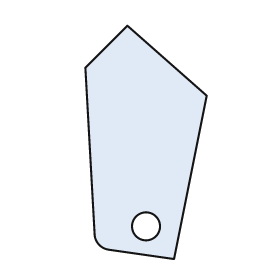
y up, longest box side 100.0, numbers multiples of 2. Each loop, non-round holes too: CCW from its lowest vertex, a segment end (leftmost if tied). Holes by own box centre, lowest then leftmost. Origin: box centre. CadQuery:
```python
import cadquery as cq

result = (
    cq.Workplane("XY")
    .moveTo(12.0, -50.0)
    .lineTo(26.0, 20.0)
    .lineTo(-8.0, 50.0)
    .lineTo(-26.0, 32.0)
    .lineTo(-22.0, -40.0)
    .threePointArc((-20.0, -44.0), (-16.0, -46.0))
    .close()
    .moveTo(0.0, -36.0)
    .circle(6.0)
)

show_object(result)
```